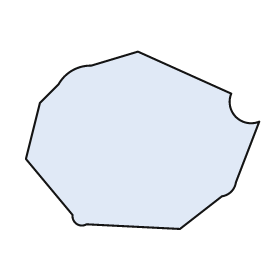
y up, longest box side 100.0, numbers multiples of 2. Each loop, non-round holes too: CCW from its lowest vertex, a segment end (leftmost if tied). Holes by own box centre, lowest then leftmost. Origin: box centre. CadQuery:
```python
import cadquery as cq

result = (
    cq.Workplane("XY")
    .moveTo(16.0, -38.0)
    .lineTo(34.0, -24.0)
    .threePointArc((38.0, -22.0), (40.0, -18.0))
    .lineTo(50.0, 8.0)
    .threePointArc((40.0, 10.0), (38.0, 20.0))
    .lineTo(-2.0, 38.0)
    .lineTo(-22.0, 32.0)
    .threePointArc((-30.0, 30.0), (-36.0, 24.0))
    .lineTo(-44.0, 16.0)
    .lineTo(-50.0, -8.0)
    .lineTo(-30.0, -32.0)
    .threePointArc((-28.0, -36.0), (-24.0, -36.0))
    .close()
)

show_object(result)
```